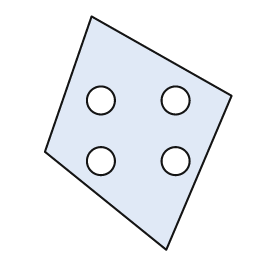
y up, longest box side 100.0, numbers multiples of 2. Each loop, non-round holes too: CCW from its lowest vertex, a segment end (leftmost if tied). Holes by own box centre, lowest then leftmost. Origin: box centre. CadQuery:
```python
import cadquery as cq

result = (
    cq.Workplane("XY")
    .moveTo(12.0, -50.0)
    .lineTo(40.0, 16.0)
    .lineTo(-20.0, 50.0)
    .lineTo(-40.0, -8.0)
    .close()
    .moveTo(-16.0, -12.0)
    .circle(6.0)
    .moveTo(16.0, -12.0)
    .circle(6.0)
    .moveTo(-16.0, 14.0)
    .circle(6.0)
    .moveTo(16.0, 14.0)
    .circle(6.0)
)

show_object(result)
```